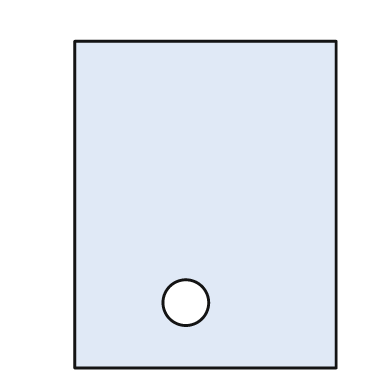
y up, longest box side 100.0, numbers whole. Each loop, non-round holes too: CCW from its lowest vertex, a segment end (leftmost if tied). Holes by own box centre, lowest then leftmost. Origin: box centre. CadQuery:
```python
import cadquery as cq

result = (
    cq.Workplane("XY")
    .moveTo(-40.0, -50.0)
    .lineTo(40.0, -50.0)
    .lineTo(40.0, 50.0)
    .lineTo(-40.0, 50.0)
    .close()
    .moveTo(-6.0, -30.0)
    .circle(7.0)
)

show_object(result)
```